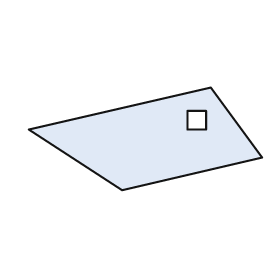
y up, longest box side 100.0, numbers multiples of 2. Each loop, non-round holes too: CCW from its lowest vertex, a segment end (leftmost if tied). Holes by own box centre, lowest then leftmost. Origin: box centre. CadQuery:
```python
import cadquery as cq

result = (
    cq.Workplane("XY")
    .moveTo(-10.0, -22.0)
    .lineTo(50.0, -8.0)
    .lineTo(28.0, 22.0)
    .lineTo(-50.0, 4.0)
    .close()
    .moveTo(18.0, 4.0)
    .lineTo(26.0, 4.0)
    .lineTo(26.0, 12.0)
    .lineTo(18.0, 12.0)
    .close()
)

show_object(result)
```